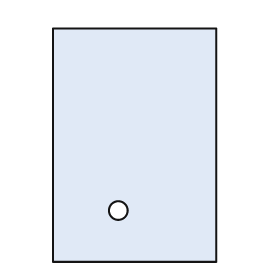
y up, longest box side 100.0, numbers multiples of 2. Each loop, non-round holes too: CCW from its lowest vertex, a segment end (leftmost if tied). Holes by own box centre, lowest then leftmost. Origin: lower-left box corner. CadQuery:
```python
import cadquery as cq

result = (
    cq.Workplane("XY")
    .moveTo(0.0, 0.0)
    .lineTo(70.0, 0.0)
    .lineTo(70.0, 100.0)
    .lineTo(0.0, 100.0)
    .close()
    .moveTo(28.0, 22.0)
    .circle(4.0)
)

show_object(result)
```